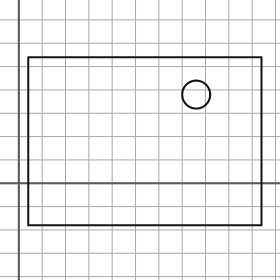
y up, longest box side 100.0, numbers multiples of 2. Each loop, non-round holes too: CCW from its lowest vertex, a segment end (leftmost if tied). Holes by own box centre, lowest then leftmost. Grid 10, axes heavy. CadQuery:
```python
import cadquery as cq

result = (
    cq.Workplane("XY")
    .moveTo(4.0, -18.0)
    .lineTo(104.0, -18.0)
    .lineTo(104.0, 54.0)
    .lineTo(4.0, 54.0)
    .close()
    .moveTo(76.0, 38.0)
    .circle(6.0)
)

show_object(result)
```